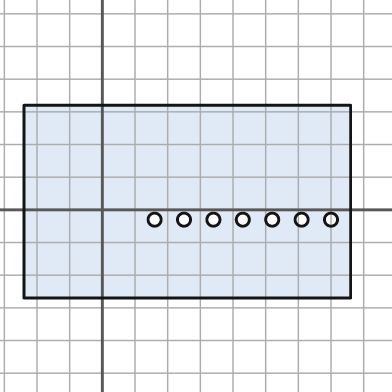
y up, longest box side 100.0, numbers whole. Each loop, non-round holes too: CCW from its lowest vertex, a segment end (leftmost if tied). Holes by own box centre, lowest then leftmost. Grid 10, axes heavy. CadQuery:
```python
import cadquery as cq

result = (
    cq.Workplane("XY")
    .moveTo(-24.0, -27.0)
    .lineTo(76.0, -27.0)
    .lineTo(76.0, 32.0)
    .lineTo(-24.0, 32.0)
    .close()
    .moveTo(16.0, -3.0)
    .circle(2.0)
    .moveTo(25.0, -3.0)
    .circle(2.0)
    .moveTo(34.0, -3.0)
    .circle(2.0)
    .moveTo(43.0, -3.0)
    .circle(2.0)
    .moveTo(52.0, -3.0)
    .circle(2.0)
    .moveTo(61.0, -3.0)
    .circle(2.0)
    .moveTo(70.0, -3.0)
    .circle(2.0)
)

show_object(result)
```